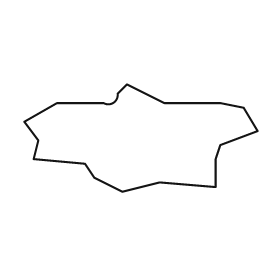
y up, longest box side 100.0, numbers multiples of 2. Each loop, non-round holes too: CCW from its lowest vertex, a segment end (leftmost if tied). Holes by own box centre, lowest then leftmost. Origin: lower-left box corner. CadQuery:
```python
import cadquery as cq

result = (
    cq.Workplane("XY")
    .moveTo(42.0, 0.0)
    .lineTo(58.0, 4.0)
    .lineTo(82.0, 2.0)
    .lineTo(82.0, 14.0)
    .lineTo(84.0, 20.0)
    .lineTo(100.0, 26.0)
    .lineTo(94.0, 36.0)
    .lineTo(84.0, 38.0)
    .lineTo(60.0, 38.0)
    .lineTo(44.0, 46.0)
    .lineTo(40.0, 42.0)
    .threePointArc((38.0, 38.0), (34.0, 38.0))
    .lineTo(14.0, 38.0)
    .lineTo(0.0, 30.0)
    .lineTo(6.0, 22.0)
    .lineTo(4.0, 14.0)
    .lineTo(26.0, 12.0)
    .lineTo(30.0, 6.0)
    .close()
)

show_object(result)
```